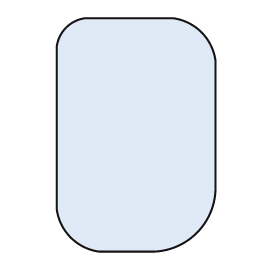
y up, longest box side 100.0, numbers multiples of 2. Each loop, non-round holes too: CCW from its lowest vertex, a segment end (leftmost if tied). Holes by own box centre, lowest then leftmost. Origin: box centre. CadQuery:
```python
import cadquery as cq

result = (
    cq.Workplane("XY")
    .moveTo(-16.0, -50.0)
    .lineTo(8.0, -50.0)
    .threePointArc((26.0, -42.0), (34.0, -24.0))
    .lineTo(34.0, 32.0)
    .threePointArc((28.0, 44.0), (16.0, 50.0))
    .lineTo(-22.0, 50.0)
    .threePointArc((-30.0, 46.0), (-34.0, 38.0))
    .lineTo(-34.0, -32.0)
    .threePointArc((-28.0, -44.0), (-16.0, -50.0))
    .close()
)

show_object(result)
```